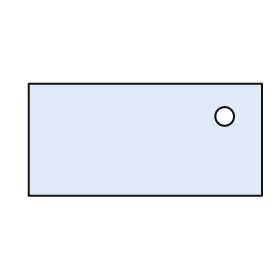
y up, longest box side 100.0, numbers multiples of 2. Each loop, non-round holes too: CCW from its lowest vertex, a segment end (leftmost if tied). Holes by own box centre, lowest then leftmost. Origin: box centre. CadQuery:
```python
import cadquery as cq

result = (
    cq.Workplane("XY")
    .moveTo(-50.0, -24.0)
    .lineTo(50.0, -24.0)
    .lineTo(50.0, 24.0)
    .lineTo(-50.0, 24.0)
    .close()
    .moveTo(34.0, 10.0)
    .circle(4.0)
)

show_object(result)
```